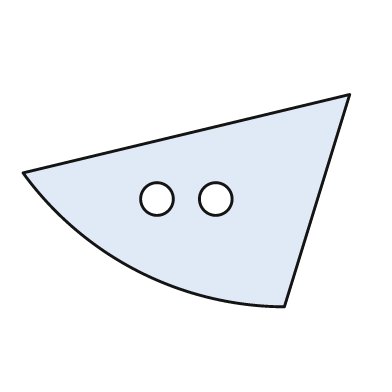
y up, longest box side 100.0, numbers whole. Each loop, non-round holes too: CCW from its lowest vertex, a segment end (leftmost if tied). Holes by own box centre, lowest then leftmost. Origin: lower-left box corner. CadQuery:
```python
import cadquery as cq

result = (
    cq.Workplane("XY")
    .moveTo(80.0, 0.0)
    .lineTo(100.0, 65.0)
    .lineTo(0.0, 41.0)
    .threePointArc((35.0, 11.0), (80.0, 0.0))
    .close()
    .moveTo(41.0, 33.0)
    .circle(5.0)
    .moveTo(59.0, 33.0)
    .circle(5.0)
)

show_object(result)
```